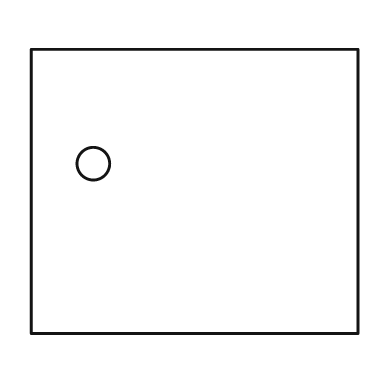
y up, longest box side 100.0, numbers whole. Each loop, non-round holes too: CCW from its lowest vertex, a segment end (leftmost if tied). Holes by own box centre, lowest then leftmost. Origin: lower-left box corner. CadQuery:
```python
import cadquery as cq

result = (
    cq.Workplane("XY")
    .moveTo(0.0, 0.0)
    .lineTo(100.0, 0.0)
    .lineTo(100.0, 87.0)
    .lineTo(0.0, 87.0)
    .close()
    .moveTo(19.0, 52.0)
    .circle(5.0)
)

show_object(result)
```